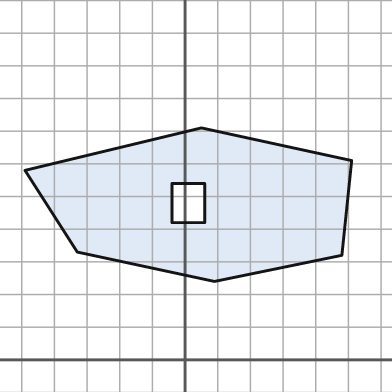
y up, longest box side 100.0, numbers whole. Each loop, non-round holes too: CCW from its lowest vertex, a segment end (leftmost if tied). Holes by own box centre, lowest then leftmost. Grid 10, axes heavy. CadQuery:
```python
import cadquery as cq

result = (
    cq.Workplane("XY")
    .moveTo(9.0, 24.0)
    .lineTo(48.0, 32.0)
    .lineTo(51.0, 61.0)
    .lineTo(5.0, 71.0)
    .lineTo(-49.0, 58.0)
    .lineTo(-33.0, 33.0)
    .close()
    .moveTo(-4.0, 42.0)
    .lineTo(6.0, 42.0)
    .lineTo(6.0, 54.0)
    .lineTo(-4.0, 54.0)
    .close()
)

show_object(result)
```